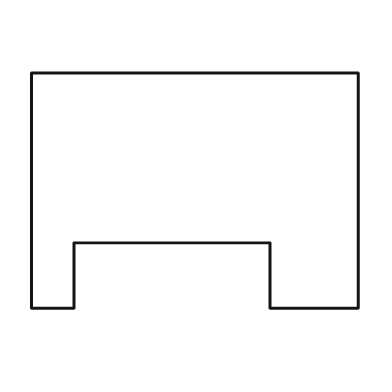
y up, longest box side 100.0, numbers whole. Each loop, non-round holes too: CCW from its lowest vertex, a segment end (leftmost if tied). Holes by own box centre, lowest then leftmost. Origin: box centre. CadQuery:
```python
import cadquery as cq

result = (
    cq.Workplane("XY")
    .moveTo(-50.0, -36.0)
    .lineTo(-37.0, -36.0)
    .lineTo(-37.0, -16.0)
    .lineTo(23.0, -16.0)
    .lineTo(23.0, -36.0)
    .lineTo(50.0, -36.0)
    .lineTo(50.0, 36.0)
    .lineTo(-50.0, 36.0)
    .close()
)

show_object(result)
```